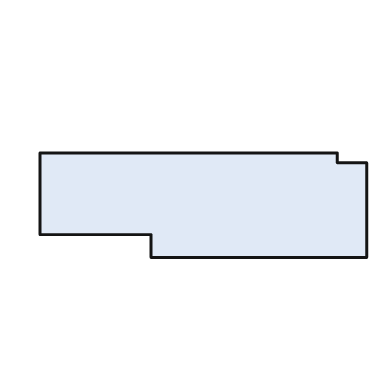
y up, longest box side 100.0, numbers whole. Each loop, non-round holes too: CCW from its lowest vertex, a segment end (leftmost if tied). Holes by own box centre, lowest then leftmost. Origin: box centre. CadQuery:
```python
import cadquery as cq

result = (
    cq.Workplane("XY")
    .moveTo(-16.0, -16.0)
    .lineTo(50.0, -16.0)
    .lineTo(50.0, 13.0)
    .lineTo(41.0, 13.0)
    .lineTo(41.0, 16.0)
    .lineTo(-50.0, 16.0)
    .lineTo(-50.0, -9.0)
    .lineTo(-16.0, -9.0)
    .close()
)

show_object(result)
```